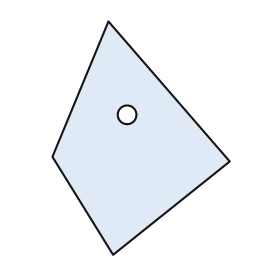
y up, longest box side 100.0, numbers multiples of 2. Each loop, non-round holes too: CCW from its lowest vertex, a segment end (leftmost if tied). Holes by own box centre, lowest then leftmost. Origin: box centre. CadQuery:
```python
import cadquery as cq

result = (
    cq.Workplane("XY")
    .moveTo(-12.0, -50.0)
    .lineTo(38.0, -10.0)
    .lineTo(-14.0, 50.0)
    .lineTo(-38.0, -8.0)
    .close()
    .moveTo(-6.0, 10.0)
    .circle(4.0)
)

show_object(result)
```